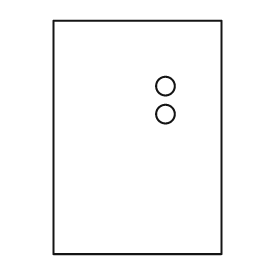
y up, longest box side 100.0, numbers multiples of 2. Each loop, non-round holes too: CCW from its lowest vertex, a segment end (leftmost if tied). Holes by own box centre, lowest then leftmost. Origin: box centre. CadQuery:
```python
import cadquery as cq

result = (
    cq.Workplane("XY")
    .moveTo(-36.0, -50.0)
    .lineTo(36.0, -50.0)
    .lineTo(36.0, 50.0)
    .lineTo(-36.0, 50.0)
    .close()
    .moveTo(12.0, 10.0)
    .circle(4.0)
    .moveTo(12.0, 22.0)
    .circle(4.0)
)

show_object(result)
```